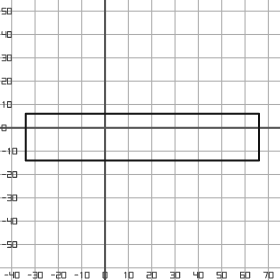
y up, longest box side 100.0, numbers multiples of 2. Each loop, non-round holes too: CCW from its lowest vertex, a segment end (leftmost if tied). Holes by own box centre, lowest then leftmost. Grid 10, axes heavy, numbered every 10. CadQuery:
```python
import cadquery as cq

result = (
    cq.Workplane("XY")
    .moveTo(-34.0, -14.0)
    .lineTo(66.0, -14.0)
    .lineTo(66.0, 6.0)
    .lineTo(-34.0, 6.0)
    .close()
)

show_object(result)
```